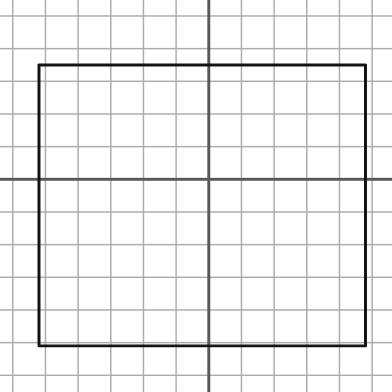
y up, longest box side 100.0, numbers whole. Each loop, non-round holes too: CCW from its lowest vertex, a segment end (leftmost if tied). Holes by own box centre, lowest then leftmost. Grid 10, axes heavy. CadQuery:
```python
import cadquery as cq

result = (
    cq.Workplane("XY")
    .moveTo(-52.0, -51.0)
    .lineTo(48.0, -51.0)
    .lineTo(48.0, 35.0)
    .lineTo(-52.0, 35.0)
    .close()
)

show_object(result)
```